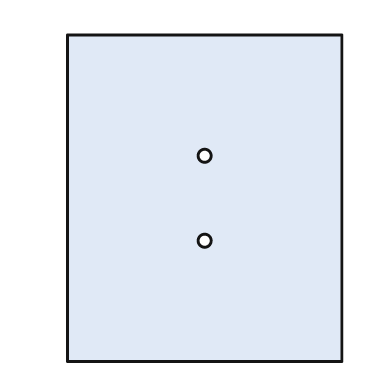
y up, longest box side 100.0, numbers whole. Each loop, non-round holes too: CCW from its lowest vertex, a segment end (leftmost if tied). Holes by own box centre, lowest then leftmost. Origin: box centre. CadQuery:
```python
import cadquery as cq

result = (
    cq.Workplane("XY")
    .moveTo(-42.0, -50.0)
    .lineTo(42.0, -50.0)
    .lineTo(42.0, 50.0)
    .lineTo(-42.0, 50.0)
    .close()
    .moveTo(0.0, -13.0)
    .circle(2.0)
    .moveTo(0.0, 13.0)
    .circle(2.0)
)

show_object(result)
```